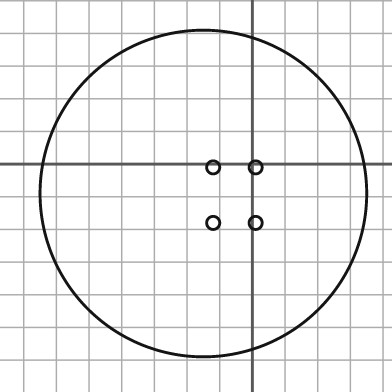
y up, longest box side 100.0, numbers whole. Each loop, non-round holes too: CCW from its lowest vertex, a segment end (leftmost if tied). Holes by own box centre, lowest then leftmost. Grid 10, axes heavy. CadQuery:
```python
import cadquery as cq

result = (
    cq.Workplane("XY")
    .moveTo(-15.0, -9.0)
    .circle(50.0)
    .moveTo(-12.0, -18.0)
    .circle(2.0)
    .moveTo(1.0, -18.0)
    .circle(2.0)
    .moveTo(-12.0, -1.0)
    .circle(2.0)
    .moveTo(1.0, -1.0)
    .circle(2.0)
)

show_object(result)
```